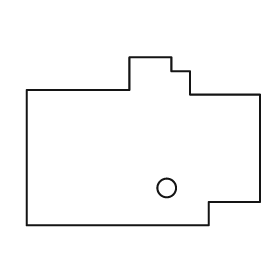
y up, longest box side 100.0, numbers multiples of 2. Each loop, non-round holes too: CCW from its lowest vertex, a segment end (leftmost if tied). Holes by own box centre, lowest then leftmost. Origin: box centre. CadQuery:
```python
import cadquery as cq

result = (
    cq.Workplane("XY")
    .moveTo(-50.0, -36.0)
    .lineTo(28.0, -36.0)
    .lineTo(28.0, -26.0)
    .lineTo(50.0, -26.0)
    .lineTo(50.0, 20.0)
    .lineTo(20.0, 20.0)
    .lineTo(20.0, 30.0)
    .lineTo(12.0, 30.0)
    .lineTo(12.0, 36.0)
    .lineTo(-6.0, 36.0)
    .lineTo(-6.0, 22.0)
    .lineTo(-50.0, 22.0)
    .close()
    .moveTo(10.0, -20.0)
    .circle(4.0)
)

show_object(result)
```